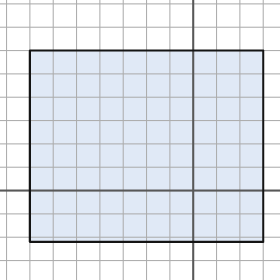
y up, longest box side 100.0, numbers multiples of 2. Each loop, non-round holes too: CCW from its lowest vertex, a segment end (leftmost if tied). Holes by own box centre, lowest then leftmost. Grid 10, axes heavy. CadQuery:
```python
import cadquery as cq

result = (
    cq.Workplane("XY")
    .moveTo(-70.0, -22.0)
    .lineTo(30.0, -22.0)
    .lineTo(30.0, 60.0)
    .lineTo(-70.0, 60.0)
    .close()
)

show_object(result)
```